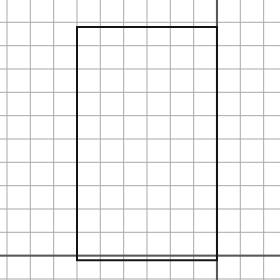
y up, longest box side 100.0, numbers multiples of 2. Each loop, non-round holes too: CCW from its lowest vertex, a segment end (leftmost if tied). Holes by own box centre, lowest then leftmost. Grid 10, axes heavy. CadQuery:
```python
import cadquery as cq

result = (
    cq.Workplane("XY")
    .moveTo(-60.0, -2.0)
    .lineTo(0.0, -2.0)
    .lineTo(0.0, 98.0)
    .lineTo(-60.0, 98.0)
    .close()
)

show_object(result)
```